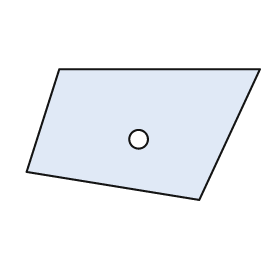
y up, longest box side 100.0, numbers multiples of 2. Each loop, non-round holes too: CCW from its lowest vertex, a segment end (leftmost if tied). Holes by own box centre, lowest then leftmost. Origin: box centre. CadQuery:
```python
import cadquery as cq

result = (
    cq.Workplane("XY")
    .moveTo(24.0, -28.0)
    .lineTo(50.0, 28.0)
    .lineTo(-36.0, 28.0)
    .lineTo(-50.0, -16.0)
    .close()
    .moveTo(-2.0, -2.0)
    .circle(4.0)
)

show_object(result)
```